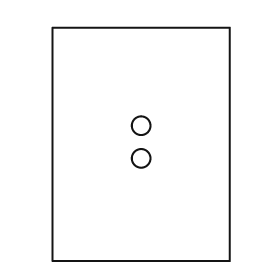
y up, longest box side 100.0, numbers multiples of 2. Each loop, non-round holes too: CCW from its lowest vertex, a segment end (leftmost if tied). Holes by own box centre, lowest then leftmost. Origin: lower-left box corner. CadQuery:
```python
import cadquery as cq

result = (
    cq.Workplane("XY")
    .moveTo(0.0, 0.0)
    .lineTo(76.0, 0.0)
    .lineTo(76.0, 100.0)
    .lineTo(0.0, 100.0)
    .close()
    .moveTo(38.0, 44.0)
    .circle(4.0)
    .moveTo(38.0, 58.0)
    .circle(4.0)
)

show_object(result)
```